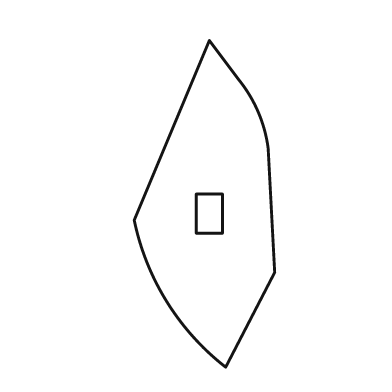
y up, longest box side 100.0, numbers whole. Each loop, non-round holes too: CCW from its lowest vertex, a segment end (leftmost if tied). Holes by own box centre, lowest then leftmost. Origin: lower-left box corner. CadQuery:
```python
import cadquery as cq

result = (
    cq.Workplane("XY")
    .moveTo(28.0, 0.0)
    .lineTo(43.0, 29.0)
    .lineTo(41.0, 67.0)
    .threePointArc((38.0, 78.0), (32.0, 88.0))
    .lineTo(23.0, 100.0)
    .lineTo(0.0, 45.0)
    .threePointArc((10.0, 20.0), (28.0, 0.0))
    .close()
    .moveTo(19.0, 41.0)
    .lineTo(27.0, 41.0)
    .lineTo(27.0, 53.0)
    .lineTo(19.0, 53.0)
    .close()
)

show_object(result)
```